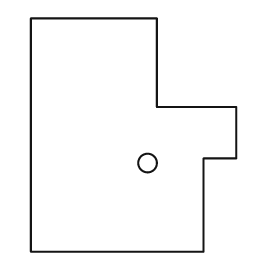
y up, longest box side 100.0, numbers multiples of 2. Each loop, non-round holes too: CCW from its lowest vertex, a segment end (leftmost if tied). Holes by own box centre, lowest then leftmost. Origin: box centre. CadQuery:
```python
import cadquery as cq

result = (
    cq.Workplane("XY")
    .moveTo(-44.0, -50.0)
    .lineTo(30.0, -50.0)
    .lineTo(30.0, -10.0)
    .lineTo(44.0, -10.0)
    .lineTo(44.0, 12.0)
    .lineTo(10.0, 12.0)
    .lineTo(10.0, 50.0)
    .lineTo(-44.0, 50.0)
    .close()
    .moveTo(6.0, -12.0)
    .circle(4.0)
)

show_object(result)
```